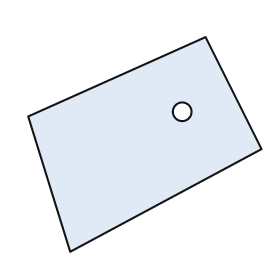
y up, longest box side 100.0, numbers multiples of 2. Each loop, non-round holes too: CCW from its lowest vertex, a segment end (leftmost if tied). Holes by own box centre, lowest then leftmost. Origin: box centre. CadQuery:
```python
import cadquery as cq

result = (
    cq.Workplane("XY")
    .moveTo(-32.0, -46.0)
    .lineTo(50.0, -2.0)
    .lineTo(26.0, 46.0)
    .lineTo(-50.0, 12.0)
    .close()
    .moveTo(16.0, 14.0)
    .circle(4.0)
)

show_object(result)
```